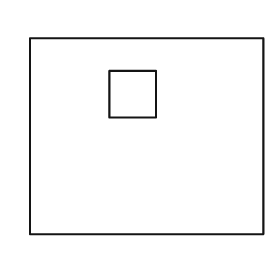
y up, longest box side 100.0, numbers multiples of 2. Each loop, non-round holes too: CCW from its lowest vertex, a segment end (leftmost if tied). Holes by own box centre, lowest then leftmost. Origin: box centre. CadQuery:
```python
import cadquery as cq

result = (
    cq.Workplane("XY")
    .moveTo(-50.0, -42.0)
    .lineTo(50.0, -42.0)
    .lineTo(50.0, 42.0)
    .lineTo(-50.0, 42.0)
    .close()
    .moveTo(-16.0, 8.0)
    .lineTo(4.0, 8.0)
    .lineTo(4.0, 28.0)
    .lineTo(-16.0, 28.0)
    .close()
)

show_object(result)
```